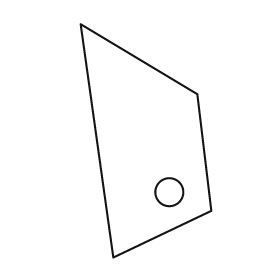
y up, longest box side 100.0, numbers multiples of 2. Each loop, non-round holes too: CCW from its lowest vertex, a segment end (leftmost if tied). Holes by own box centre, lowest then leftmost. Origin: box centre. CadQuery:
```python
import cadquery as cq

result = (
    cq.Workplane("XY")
    .moveTo(-14.0, -50.0)
    .lineTo(28.0, -30.0)
    .lineTo(22.0, 20.0)
    .lineTo(-28.0, 50.0)
    .close()
    .moveTo(10.0, -22.0)
    .circle(6.0)
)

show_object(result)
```